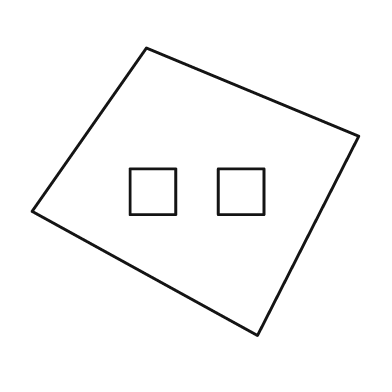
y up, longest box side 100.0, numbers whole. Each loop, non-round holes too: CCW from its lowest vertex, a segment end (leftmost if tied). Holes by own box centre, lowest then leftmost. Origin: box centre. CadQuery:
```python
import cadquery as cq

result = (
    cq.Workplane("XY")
    .moveTo(19.0, -44.0)
    .lineTo(50.0, 17.0)
    .lineTo(-15.0, 44.0)
    .lineTo(-50.0, -6.0)
    .close()
    .moveTo(-20.0, -7.0)
    .lineTo(-6.0, -7.0)
    .lineTo(-6.0, 7.0)
    .lineTo(-20.0, 7.0)
    .close()
    .moveTo(7.0, -7.0)
    .lineTo(21.0, -7.0)
    .lineTo(21.0, 7.0)
    .lineTo(7.0, 7.0)
    .close()
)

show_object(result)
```